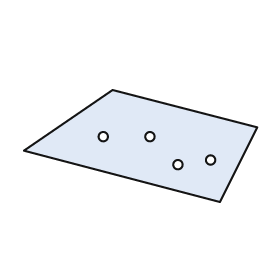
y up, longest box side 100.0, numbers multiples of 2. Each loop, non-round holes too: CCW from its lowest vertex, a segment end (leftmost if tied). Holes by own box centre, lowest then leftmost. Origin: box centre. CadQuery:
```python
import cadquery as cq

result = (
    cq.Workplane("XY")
    .moveTo(34.0, -24.0)
    .lineTo(50.0, 8.0)
    .lineTo(-12.0, 24.0)
    .lineTo(-50.0, -2.0)
    .close()
    .moveTo(16.0, -8.0)
    .circle(2.0)
    .moveTo(30.0, -6.0)
    .circle(2.0)
    .moveTo(-16.0, 4.0)
    .circle(2.0)
    .moveTo(4.0, 4.0)
    .circle(2.0)
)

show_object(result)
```